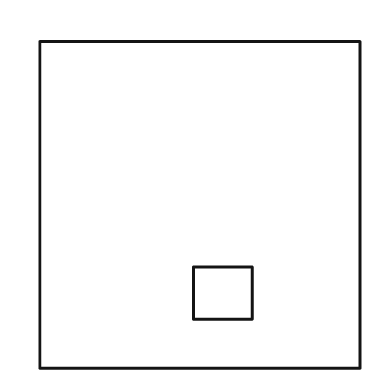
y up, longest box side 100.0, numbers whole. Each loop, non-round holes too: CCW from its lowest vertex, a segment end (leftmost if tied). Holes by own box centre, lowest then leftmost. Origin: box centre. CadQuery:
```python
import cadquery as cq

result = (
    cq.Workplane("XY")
    .moveTo(-49.0, -50.0)
    .lineTo(49.0, -50.0)
    .lineTo(49.0, 50.0)
    .lineTo(-49.0, 50.0)
    .close()
    .moveTo(-2.0, -35.0)
    .lineTo(16.0, -35.0)
    .lineTo(16.0, -19.0)
    .lineTo(-2.0, -19.0)
    .close()
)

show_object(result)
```